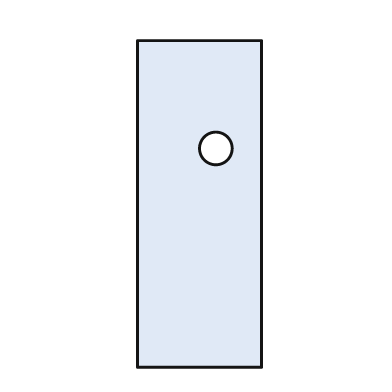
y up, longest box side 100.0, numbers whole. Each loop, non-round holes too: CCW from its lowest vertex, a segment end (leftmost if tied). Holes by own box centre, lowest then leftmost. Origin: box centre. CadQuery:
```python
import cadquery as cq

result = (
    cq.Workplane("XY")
    .moveTo(-19.0, -50.0)
    .lineTo(19.0, -50.0)
    .lineTo(19.0, 50.0)
    .lineTo(-19.0, 50.0)
    .close()
    .moveTo(5.0, 17.0)
    .circle(5.0)
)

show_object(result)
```